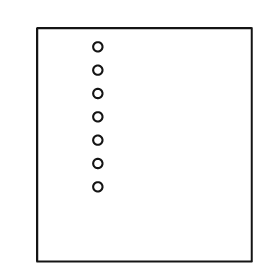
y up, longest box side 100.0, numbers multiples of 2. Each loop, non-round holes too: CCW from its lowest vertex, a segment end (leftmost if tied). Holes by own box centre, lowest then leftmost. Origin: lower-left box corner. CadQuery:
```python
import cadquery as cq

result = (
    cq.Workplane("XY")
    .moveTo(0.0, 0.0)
    .lineTo(92.0, 0.0)
    .lineTo(92.0, 100.0)
    .lineTo(0.0, 100.0)
    .close()
    .moveTo(26.0, 32.0)
    .circle(2.0)
    .moveTo(26.0, 42.0)
    .circle(2.0)
    .moveTo(26.0, 52.0)
    .circle(2.0)
    .moveTo(26.0, 62.0)
    .circle(2.0)
    .moveTo(26.0, 72.0)
    .circle(2.0)
    .moveTo(26.0, 82.0)
    .circle(2.0)
    .moveTo(26.0, 92.0)
    .circle(2.0)
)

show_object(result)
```